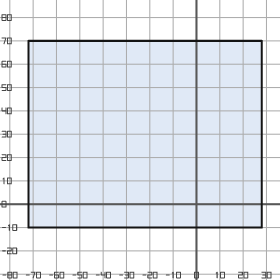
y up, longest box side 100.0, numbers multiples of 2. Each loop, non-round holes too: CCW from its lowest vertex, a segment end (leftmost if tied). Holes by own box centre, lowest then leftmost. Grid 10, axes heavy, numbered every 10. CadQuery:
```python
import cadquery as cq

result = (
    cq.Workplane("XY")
    .moveTo(-72.0, -10.0)
    .lineTo(28.0, -10.0)
    .lineTo(28.0, 70.0)
    .lineTo(-72.0, 70.0)
    .close()
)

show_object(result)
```